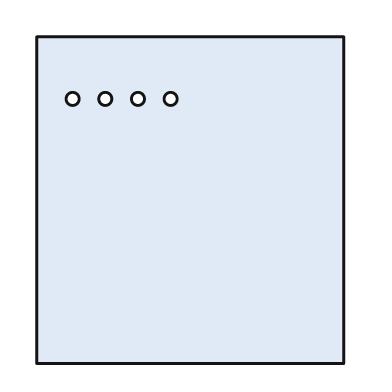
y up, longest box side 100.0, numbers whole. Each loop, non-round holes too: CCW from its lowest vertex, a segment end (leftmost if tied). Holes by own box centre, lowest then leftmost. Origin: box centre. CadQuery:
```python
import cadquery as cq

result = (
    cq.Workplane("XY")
    .moveTo(-47.0, -50.0)
    .lineTo(47.0, -50.0)
    .lineTo(47.0, 50.0)
    .lineTo(-47.0, 50.0)
    .close()
    .moveTo(-36.0, 31.0)
    .circle(2.0)
    .moveTo(-26.0, 31.0)
    .circle(2.0)
    .moveTo(-16.0, 31.0)
    .circle(2.0)
    .moveTo(-6.0, 31.0)
    .circle(2.0)
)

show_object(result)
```